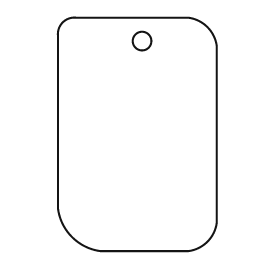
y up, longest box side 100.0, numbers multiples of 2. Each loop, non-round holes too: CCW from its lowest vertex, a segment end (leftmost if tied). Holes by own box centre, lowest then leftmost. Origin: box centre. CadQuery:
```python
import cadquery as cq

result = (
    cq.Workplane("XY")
    .moveTo(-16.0, -50.0)
    .lineTo(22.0, -50.0)
    .threePointArc((30.0, -46.0), (34.0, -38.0))
    .lineTo(34.0, 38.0)
    .threePointArc((30.0, 46.0), (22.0, 50.0))
    .lineTo(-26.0, 50.0)
    .threePointArc((-32.0, 48.0), (-34.0, 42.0))
    .lineTo(-34.0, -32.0)
    .threePointArc((-28.0, -44.0), (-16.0, -50.0))
    .close()
    .moveTo(2.0, 40.0)
    .circle(4.0)
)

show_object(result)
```